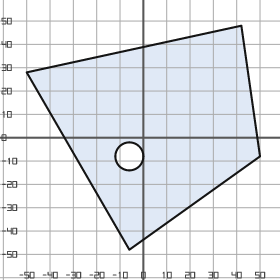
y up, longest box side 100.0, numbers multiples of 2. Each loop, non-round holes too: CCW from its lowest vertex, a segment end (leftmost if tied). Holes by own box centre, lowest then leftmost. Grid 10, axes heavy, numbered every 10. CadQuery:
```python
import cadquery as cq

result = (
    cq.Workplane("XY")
    .moveTo(-6.0, -48.0)
    .lineTo(50.0, -8.0)
    .lineTo(42.0, 48.0)
    .lineTo(-50.0, 28.0)
    .close()
    .moveTo(-6.0, -8.0)
    .circle(6.0)
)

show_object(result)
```